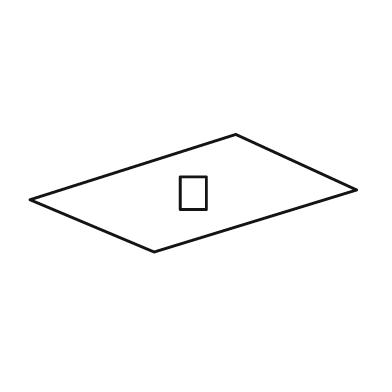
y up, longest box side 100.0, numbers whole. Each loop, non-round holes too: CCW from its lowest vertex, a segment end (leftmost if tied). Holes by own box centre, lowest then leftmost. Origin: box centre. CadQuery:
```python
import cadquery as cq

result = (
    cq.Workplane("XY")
    .moveTo(-12.0, -18.0)
    .lineTo(50.0, 1.0)
    .lineTo(13.0, 18.0)
    .lineTo(-50.0, -2.0)
    .close()
    .moveTo(-4.0, -5.0)
    .lineTo(4.0, -5.0)
    .lineTo(4.0, 5.0)
    .lineTo(-4.0, 5.0)
    .close()
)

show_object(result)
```